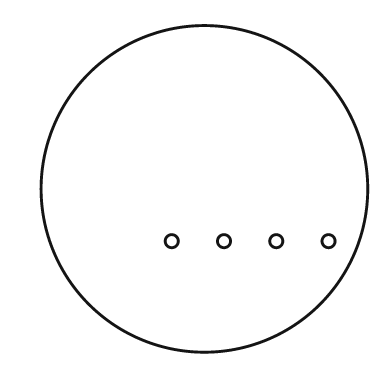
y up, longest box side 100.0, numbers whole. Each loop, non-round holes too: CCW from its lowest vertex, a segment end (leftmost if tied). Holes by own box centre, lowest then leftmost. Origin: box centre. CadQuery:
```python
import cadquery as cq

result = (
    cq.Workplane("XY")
    .moveTo(0.0, 0.0)
    .circle(50.0)
    .moveTo(-10.0, -16.0)
    .circle(2.0)
    .moveTo(6.0, -16.0)
    .circle(2.0)
    .moveTo(22.0, -16.0)
    .circle(2.0)
    .moveTo(38.0, -16.0)
    .circle(2.0)
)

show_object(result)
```